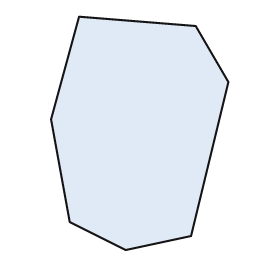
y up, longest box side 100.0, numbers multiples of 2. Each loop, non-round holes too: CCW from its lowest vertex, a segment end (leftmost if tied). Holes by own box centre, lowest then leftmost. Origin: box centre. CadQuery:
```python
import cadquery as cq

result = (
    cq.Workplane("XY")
    .moveTo(-6.0, -50.0)
    .lineTo(22.0, -44.0)
    .lineTo(38.0, 22.0)
    .lineTo(24.0, 46.0)
    .lineTo(-26.0, 50.0)
    .lineTo(-38.0, 6.0)
    .lineTo(-30.0, -38.0)
    .close()
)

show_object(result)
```